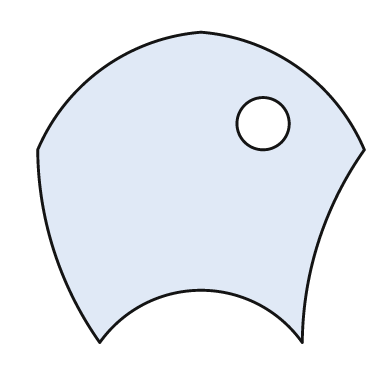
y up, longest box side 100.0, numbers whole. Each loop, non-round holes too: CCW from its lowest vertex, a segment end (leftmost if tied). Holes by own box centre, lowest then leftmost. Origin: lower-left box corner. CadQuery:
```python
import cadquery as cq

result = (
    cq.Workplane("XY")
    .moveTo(19.0, 0.0)
    .threePointArc((50.0, 16.0), (81.0, 0.0))
    .threePointArc((86.0, 31.0), (100.0, 59.0))
    .threePointArc((80.0, 84.0), (50.0, 95.0))
    .threePointArc((20.0, 84.0), (0.0, 59.0))
    .threePointArc((5.0, 28.0), (19.0, 0.0))
    .close()
    .moveTo(69.0, 67.0)
    .circle(8.0)
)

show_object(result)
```